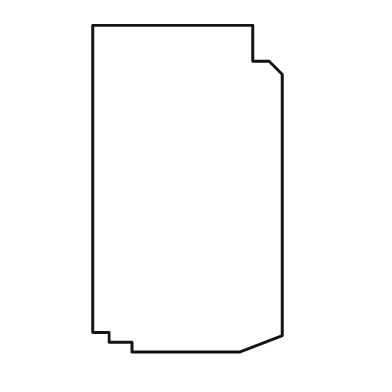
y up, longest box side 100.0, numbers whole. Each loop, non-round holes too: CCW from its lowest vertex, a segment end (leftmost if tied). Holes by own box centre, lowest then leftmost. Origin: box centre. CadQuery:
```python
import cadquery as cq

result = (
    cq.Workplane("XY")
    .moveTo(-17.0, -50.0)
    .lineTo(16.0, -50.0)
    .lineTo(29.0, -45.0)
    .lineTo(29.0, 35.0)
    .lineTo(25.0, 39.0)
    .lineTo(20.0, 39.0)
    .lineTo(20.0, 50.0)
    .lineTo(-29.0, 50.0)
    .lineTo(-29.0, -44.0)
    .lineTo(-24.0, -44.0)
    .lineTo(-24.0, -47.0)
    .lineTo(-17.0, -47.0)
    .close()
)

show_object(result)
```